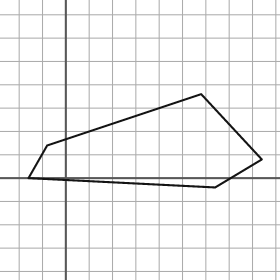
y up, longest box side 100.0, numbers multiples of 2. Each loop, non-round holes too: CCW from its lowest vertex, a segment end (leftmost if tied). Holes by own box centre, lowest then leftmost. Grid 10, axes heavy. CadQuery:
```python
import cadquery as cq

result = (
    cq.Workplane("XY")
    .moveTo(64.0, -4.0)
    .lineTo(84.0, 8.0)
    .lineTo(58.0, 36.0)
    .lineTo(-8.0, 14.0)
    .lineTo(-16.0, 0.0)
    .close()
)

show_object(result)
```